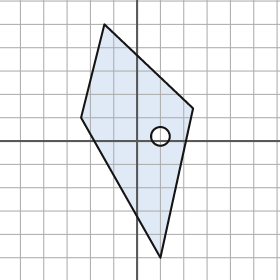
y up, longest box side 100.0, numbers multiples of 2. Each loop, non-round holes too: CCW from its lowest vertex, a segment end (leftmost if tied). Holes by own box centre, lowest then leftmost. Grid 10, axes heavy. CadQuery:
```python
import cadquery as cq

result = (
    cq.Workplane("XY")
    .moveTo(10.0, -50.0)
    .lineTo(24.0, 14.0)
    .lineTo(-14.0, 50.0)
    .lineTo(-24.0, 10.0)
    .close()
    .moveTo(10.0, 2.0)
    .circle(4.0)
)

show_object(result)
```